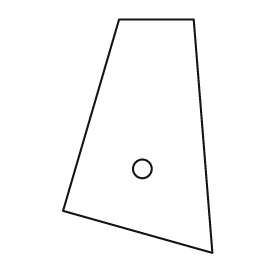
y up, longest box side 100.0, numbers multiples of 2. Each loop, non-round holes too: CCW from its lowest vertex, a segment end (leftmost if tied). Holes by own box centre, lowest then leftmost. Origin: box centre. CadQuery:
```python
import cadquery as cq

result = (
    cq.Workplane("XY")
    .moveTo(32.0, -50.0)
    .lineTo(24.0, 50.0)
    .lineTo(-8.0, 50.0)
    .lineTo(-32.0, -32.0)
    .close()
    .moveTo(2.0, -14.0)
    .circle(4.0)
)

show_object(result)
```